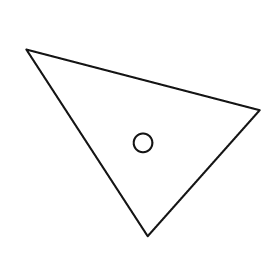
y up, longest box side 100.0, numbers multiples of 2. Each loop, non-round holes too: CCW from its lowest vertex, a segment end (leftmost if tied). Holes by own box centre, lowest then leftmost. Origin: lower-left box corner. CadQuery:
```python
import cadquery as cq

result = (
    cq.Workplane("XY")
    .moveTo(52.0, 0.0)
    .lineTo(100.0, 54.0)
    .lineTo(0.0, 80.0)
    .close()
    .moveTo(50.0, 40.0)
    .circle(4.0)
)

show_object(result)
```